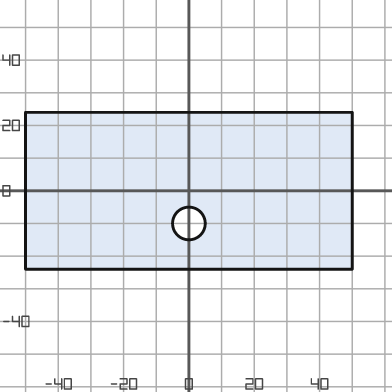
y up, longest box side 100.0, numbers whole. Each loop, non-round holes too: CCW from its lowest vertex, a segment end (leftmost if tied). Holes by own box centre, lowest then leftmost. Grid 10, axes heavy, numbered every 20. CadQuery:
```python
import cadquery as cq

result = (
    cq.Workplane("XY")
    .moveTo(-50.0, -24.0)
    .lineTo(50.0, -24.0)
    .lineTo(50.0, 24.0)
    .lineTo(-50.0, 24.0)
    .close()
    .moveTo(0.0, -10.0)
    .circle(5.0)
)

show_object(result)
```